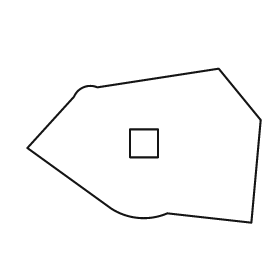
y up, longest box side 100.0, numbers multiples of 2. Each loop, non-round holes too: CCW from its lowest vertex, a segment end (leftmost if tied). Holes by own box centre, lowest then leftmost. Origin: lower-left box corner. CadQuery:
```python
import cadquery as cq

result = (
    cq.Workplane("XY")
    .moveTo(96.0, 0.0)
    .lineTo(100.0, 44.0)
    .lineTo(82.0, 66.0)
    .lineTo(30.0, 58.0)
    .threePointArc((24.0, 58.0), (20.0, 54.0))
    .lineTo(0.0, 32.0)
    .lineTo(36.0, 6.0)
    .threePointArc((48.0, 2.0), (60.0, 4.0))
    .close()
    .moveTo(44.0, 28.0)
    .lineTo(56.0, 28.0)
    .lineTo(56.0, 40.0)
    .lineTo(44.0, 40.0)
    .close()
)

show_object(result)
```